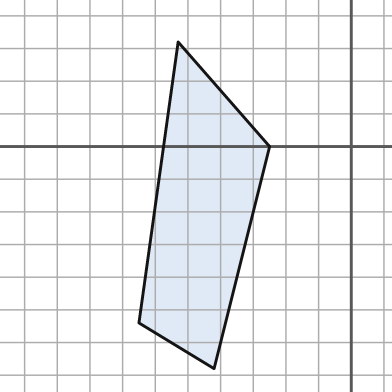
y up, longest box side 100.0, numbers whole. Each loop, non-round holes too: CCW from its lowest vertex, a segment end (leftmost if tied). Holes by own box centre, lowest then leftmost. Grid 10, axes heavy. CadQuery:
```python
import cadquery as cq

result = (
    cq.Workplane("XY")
    .moveTo(-42.0, -68.0)
    .lineTo(-25.0, 0.0)
    .lineTo(-53.0, 32.0)
    .lineTo(-65.0, -54.0)
    .close()
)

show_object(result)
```